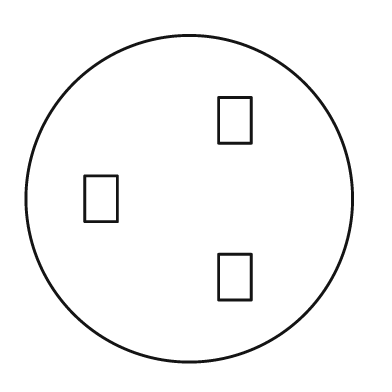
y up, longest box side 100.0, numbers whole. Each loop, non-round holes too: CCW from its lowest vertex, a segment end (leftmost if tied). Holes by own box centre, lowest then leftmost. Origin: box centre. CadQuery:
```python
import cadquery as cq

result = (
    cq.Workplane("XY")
    .moveTo(0.0, 0.0)
    .circle(50.0)
    .moveTo(9.0, -31.0)
    .lineTo(19.0, -31.0)
    .lineTo(19.0, -17.0)
    .lineTo(9.0, -17.0)
    .close()
    .moveTo(-32.0, -7.0)
    .lineTo(-22.0, -7.0)
    .lineTo(-22.0, 7.0)
    .lineTo(-32.0, 7.0)
    .close()
    .moveTo(9.0, 17.0)
    .lineTo(19.0, 17.0)
    .lineTo(19.0, 31.0)
    .lineTo(9.0, 31.0)
    .close()
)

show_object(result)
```